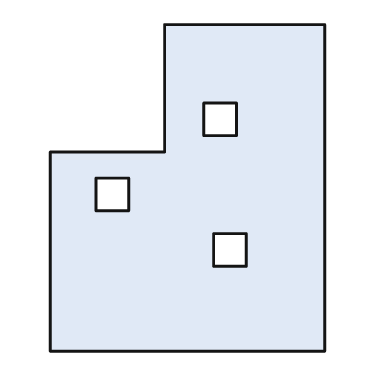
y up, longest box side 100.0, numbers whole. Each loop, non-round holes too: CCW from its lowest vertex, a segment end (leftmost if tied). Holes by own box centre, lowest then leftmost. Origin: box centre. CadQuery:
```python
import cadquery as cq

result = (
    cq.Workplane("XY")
    .moveTo(-42.0, -50.0)
    .lineTo(42.0, -50.0)
    .lineTo(42.0, 50.0)
    .lineTo(-7.0, 50.0)
    .lineTo(-7.0, 11.0)
    .lineTo(-42.0, 11.0)
    .close()
    .moveTo(8.0, -24.0)
    .lineTo(18.0, -24.0)
    .lineTo(18.0, -14.0)
    .lineTo(8.0, -14.0)
    .close()
    .moveTo(-28.0, -7.0)
    .lineTo(-18.0, -7.0)
    .lineTo(-18.0, 3.0)
    .lineTo(-28.0, 3.0)
    .close()
    .moveTo(5.0, 16.0)
    .lineTo(15.0, 16.0)
    .lineTo(15.0, 26.0)
    .lineTo(5.0, 26.0)
    .close()
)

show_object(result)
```